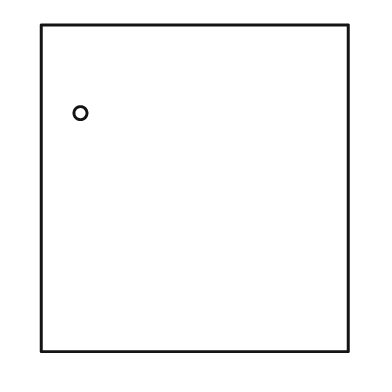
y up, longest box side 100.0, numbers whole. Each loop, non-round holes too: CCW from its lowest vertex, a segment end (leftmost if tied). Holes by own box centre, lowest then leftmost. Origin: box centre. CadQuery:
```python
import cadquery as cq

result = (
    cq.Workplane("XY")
    .moveTo(-47.0, -50.0)
    .lineTo(47.0, -50.0)
    .lineTo(47.0, 50.0)
    .lineTo(-47.0, 50.0)
    .close()
    .moveTo(-35.0, 23.0)
    .circle(2.0)
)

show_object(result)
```